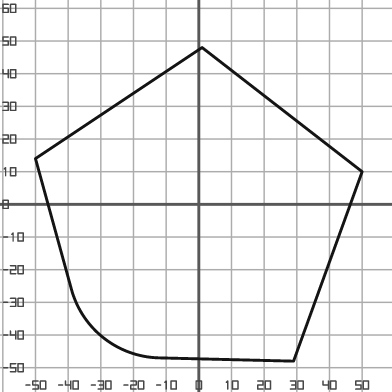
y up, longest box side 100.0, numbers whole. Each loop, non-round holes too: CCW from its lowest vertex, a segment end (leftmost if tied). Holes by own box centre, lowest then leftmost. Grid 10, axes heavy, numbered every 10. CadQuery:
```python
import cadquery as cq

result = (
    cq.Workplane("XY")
    .moveTo(29.0, -48.0)
    .lineTo(50.0, 10.0)
    .lineTo(1.0, 48.0)
    .lineTo(-50.0, 14.0)
    .lineTo(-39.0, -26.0)
    .threePointArc((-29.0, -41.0), (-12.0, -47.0))
    .close()
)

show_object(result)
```